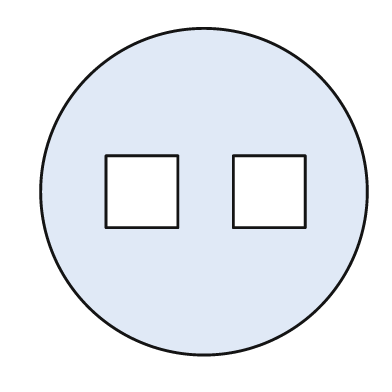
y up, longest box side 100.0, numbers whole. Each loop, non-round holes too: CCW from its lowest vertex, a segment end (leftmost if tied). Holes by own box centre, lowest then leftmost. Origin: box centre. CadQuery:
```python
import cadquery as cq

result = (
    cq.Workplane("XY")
    .moveTo(0.0, 0.0)
    .circle(50.0)
    .moveTo(-30.0, -11.0)
    .lineTo(-8.0, -11.0)
    .lineTo(-8.0, 11.0)
    .lineTo(-30.0, 11.0)
    .close()
    .moveTo(9.0, -11.0)
    .lineTo(31.0, -11.0)
    .lineTo(31.0, 11.0)
    .lineTo(9.0, 11.0)
    .close()
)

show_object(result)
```